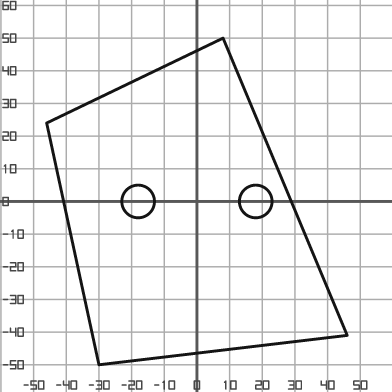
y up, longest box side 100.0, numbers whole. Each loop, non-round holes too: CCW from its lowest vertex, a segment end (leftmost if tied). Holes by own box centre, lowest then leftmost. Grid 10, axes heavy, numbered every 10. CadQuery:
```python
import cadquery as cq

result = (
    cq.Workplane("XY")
    .moveTo(-30.0, -50.0)
    .lineTo(46.0, -41.0)
    .lineTo(8.0, 50.0)
    .lineTo(-46.0, 24.0)
    .close()
    .moveTo(-18.0, 0.0)
    .circle(5.0)
    .moveTo(18.0, 0.0)
    .circle(5.0)
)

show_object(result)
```